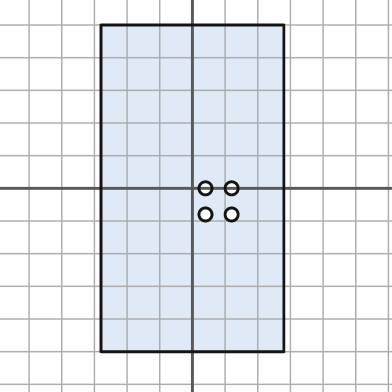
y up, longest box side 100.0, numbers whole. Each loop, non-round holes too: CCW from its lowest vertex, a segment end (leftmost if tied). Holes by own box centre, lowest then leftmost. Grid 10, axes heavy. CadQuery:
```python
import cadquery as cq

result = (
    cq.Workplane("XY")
    .moveTo(-28.0, -50.0)
    .lineTo(28.0, -50.0)
    .lineTo(28.0, 50.0)
    .lineTo(-28.0, 50.0)
    .close()
    .moveTo(4.0, -8.0)
    .circle(2.0)
    .moveTo(12.0, -8.0)
    .circle(2.0)
    .moveTo(4.0, 0.0)
    .circle(2.0)
    .moveTo(12.0, 0.0)
    .circle(2.0)
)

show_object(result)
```